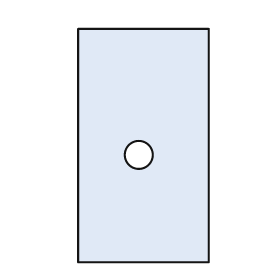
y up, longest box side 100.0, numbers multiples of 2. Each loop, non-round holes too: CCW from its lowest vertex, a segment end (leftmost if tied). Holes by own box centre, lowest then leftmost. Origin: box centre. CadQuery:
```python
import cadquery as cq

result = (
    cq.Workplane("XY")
    .moveTo(-28.0, -50.0)
    .lineTo(28.0, -50.0)
    .lineTo(28.0, 50.0)
    .lineTo(-28.0, 50.0)
    .close()
    .moveTo(-2.0, -4.0)
    .circle(6.0)
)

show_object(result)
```